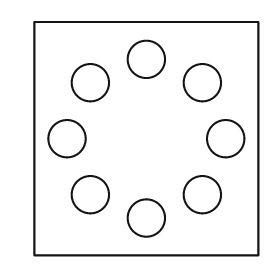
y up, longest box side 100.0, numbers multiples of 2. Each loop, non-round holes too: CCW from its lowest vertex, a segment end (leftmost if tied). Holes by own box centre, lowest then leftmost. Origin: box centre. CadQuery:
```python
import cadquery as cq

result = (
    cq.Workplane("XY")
    .moveTo(-48.0, -50.0)
    .lineTo(48.0, -50.0)
    .lineTo(48.0, 50.0)
    .lineTo(-48.0, 50.0)
    .close()
    .moveTo(0.0, -34.0)
    .circle(8.0)
    .moveTo(-24.0, -24.0)
    .circle(8.0)
    .moveTo(24.0, -24.0)
    .circle(8.0)
    .moveTo(-34.0, 0.0)
    .circle(8.0)
    .moveTo(34.0, 0.0)
    .circle(8.0)
    .moveTo(-24.0, 24.0)
    .circle(8.0)
    .moveTo(24.0, 24.0)
    .circle(8.0)
    .moveTo(0.0, 34.0)
    .circle(8.0)
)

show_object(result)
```